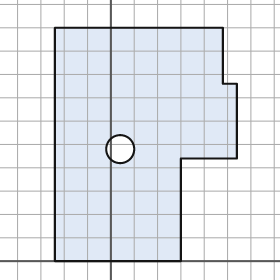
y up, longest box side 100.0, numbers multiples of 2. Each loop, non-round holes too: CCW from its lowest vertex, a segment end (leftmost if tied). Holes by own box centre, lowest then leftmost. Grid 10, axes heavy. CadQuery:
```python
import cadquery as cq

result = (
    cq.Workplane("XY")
    .moveTo(-24.0, 0.0)
    .lineTo(30.0, 0.0)
    .lineTo(30.0, 44.0)
    .lineTo(54.0, 44.0)
    .lineTo(54.0, 76.0)
    .lineTo(48.0, 76.0)
    .lineTo(48.0, 100.0)
    .lineTo(-24.0, 100.0)
    .close()
    .moveTo(4.0, 48.0)
    .circle(6.0)
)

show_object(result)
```